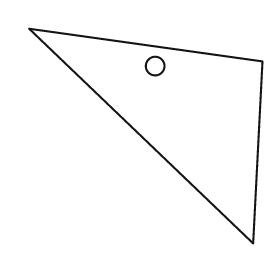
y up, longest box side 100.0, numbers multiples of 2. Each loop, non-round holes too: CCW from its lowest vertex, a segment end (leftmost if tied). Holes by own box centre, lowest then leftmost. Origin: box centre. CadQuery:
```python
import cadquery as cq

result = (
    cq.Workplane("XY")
    .moveTo(46.0, -46.0)
    .lineTo(50.0, 32.0)
    .lineTo(-50.0, 46.0)
    .close()
    .moveTo(4.0, 30.0)
    .circle(4.0)
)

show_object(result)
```